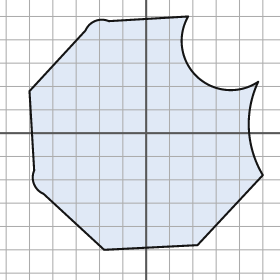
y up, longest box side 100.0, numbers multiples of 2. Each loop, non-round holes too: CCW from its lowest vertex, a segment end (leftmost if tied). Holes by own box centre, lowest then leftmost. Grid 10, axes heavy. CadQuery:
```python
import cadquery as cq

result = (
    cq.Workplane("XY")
    .moveTo(-18.0, -50.0)
    .lineTo(22.0, -48.0)
    .lineTo(50.0, -18.0)
    .threePointArc((44.0, 2.0), (48.0, 22.0))
    .threePointArc((22.0, 24.0), (18.0, 50.0))
    .lineTo(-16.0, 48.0)
    .threePointArc((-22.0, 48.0), (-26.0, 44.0))
    .lineTo(-50.0, 18.0)
    .lineTo(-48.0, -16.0)
    .threePointArc((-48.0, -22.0), (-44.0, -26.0))
    .close()
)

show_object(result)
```